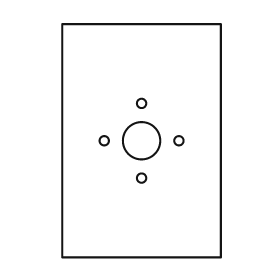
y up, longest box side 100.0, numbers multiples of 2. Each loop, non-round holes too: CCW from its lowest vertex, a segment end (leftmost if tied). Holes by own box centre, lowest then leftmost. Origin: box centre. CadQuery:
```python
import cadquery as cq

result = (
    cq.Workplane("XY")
    .moveTo(-34.0, -50.0)
    .lineTo(34.0, -50.0)
    .lineTo(34.0, 50.0)
    .lineTo(-34.0, 50.0)
    .close()
    .moveTo(0.0, -16.0)
    .circle(2.0)
    .moveTo(-16.0, 0.0)
    .circle(2.0)
    .moveTo(0.0, 0.0)
    .circle(8.0)
    .moveTo(16.0, 0.0)
    .circle(2.0)
    .moveTo(0.0, 16.0)
    .circle(2.0)
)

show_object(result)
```